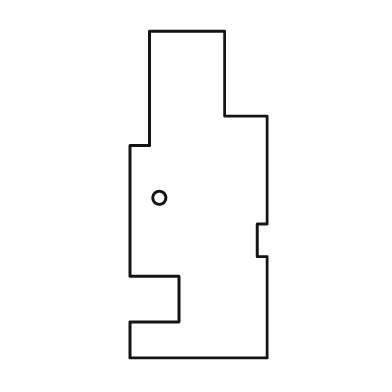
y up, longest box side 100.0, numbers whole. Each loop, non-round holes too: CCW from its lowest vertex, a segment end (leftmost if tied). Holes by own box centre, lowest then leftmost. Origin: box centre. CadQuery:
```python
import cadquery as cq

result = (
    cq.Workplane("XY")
    .moveTo(-21.0, -50.0)
    .lineTo(21.0, -50.0)
    .lineTo(21.0, -19.0)
    .lineTo(18.0, -19.0)
    .lineTo(18.0, -9.0)
    .lineTo(21.0, -9.0)
    .lineTo(21.0, 24.0)
    .lineTo(8.0, 24.0)
    .lineTo(8.0, 50.0)
    .lineTo(-15.0, 50.0)
    .lineTo(-15.0, 15.0)
    .lineTo(-21.0, 15.0)
    .lineTo(-21.0, -25.0)
    .lineTo(-6.0, -25.0)
    .lineTo(-6.0, -39.0)
    .lineTo(-21.0, -39.0)
    .close()
    .moveTo(-12.0, -1.0)
    .circle(2.0)
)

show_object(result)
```